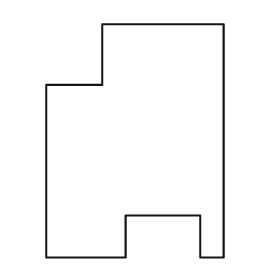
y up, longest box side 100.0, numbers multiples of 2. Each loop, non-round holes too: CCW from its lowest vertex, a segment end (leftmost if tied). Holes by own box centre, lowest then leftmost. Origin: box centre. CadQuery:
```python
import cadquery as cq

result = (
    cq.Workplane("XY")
    .moveTo(-38.0, -50.0)
    .lineTo(-4.0, -50.0)
    .lineTo(-4.0, -32.0)
    .lineTo(28.0, -32.0)
    .lineTo(28.0, -50.0)
    .lineTo(38.0, -50.0)
    .lineTo(38.0, 50.0)
    .lineTo(-14.0, 50.0)
    .lineTo(-14.0, 24.0)
    .lineTo(-38.0, 24.0)
    .close()
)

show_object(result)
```